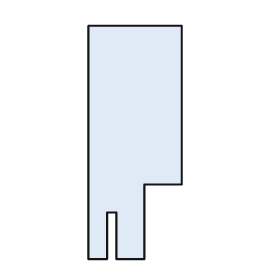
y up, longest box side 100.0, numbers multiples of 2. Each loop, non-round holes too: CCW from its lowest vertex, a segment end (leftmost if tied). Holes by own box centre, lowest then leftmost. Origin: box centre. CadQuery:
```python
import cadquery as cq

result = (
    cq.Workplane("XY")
    .moveTo(-20.0, -50.0)
    .lineTo(-12.0, -50.0)
    .lineTo(-12.0, -30.0)
    .lineTo(-8.0, -30.0)
    .lineTo(-8.0, -50.0)
    .lineTo(4.0, -50.0)
    .lineTo(4.0, -18.0)
    .lineTo(20.0, -18.0)
    .lineTo(20.0, 50.0)
    .lineTo(-20.0, 50.0)
    .close()
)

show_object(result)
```